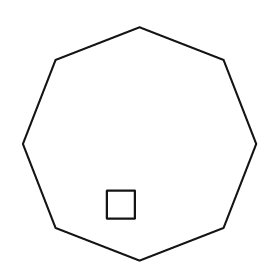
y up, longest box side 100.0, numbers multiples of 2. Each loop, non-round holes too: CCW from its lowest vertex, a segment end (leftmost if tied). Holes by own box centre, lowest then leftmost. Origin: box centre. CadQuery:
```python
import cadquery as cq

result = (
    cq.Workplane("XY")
    .moveTo(0.0, -50.0)
    .lineTo(36.0, -36.0)
    .lineTo(50.0, 0.0)
    .lineTo(36.0, 36.0)
    .lineTo(0.0, 50.0)
    .lineTo(-36.0, 36.0)
    .lineTo(-50.0, 0.0)
    .lineTo(-36.0, -36.0)
    .close()
    .moveTo(-14.0, -32.0)
    .lineTo(-2.0, -32.0)
    .lineTo(-2.0, -20.0)
    .lineTo(-14.0, -20.0)
    .close()
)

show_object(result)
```